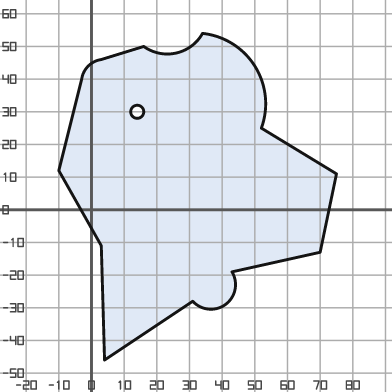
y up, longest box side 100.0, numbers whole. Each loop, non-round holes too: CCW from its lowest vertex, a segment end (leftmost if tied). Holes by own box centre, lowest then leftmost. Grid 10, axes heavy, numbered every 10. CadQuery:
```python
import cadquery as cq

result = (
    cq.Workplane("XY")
    .moveTo(4.0, -46.0)
    .lineTo(31.0, -28.0)
    .threePointArc((41.0, -29.0), (43.0, -19.0))
    .lineTo(70.0, -13.0)
    .lineTo(75.0, 11.0)
    .lineTo(52.0, 25.0)
    .threePointArc((50.0, 44.0), (34.0, 54.0))
    .threePointArc((26.0, 48.0), (16.0, 50.0))
    .lineTo(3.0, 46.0)
    .threePointArc((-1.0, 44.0), (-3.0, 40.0))
    .lineTo(-10.0, 12.0)
    .lineTo(3.0, -11.0)
    .close()
    .moveTo(14.0, 30.0)
    .circle(2.0)
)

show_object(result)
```